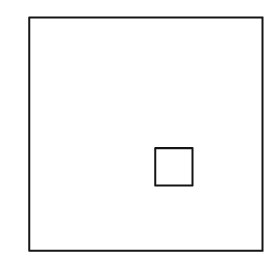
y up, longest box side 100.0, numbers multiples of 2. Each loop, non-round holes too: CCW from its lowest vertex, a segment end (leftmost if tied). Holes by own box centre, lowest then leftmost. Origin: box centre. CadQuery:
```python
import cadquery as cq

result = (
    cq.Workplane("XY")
    .moveTo(-50.0, -50.0)
    .lineTo(50.0, -50.0)
    .lineTo(50.0, 50.0)
    .lineTo(-50.0, 50.0)
    .close()
    .moveTo(4.0, -22.0)
    .lineTo(20.0, -22.0)
    .lineTo(20.0, -6.0)
    .lineTo(4.0, -6.0)
    .close()
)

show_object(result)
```